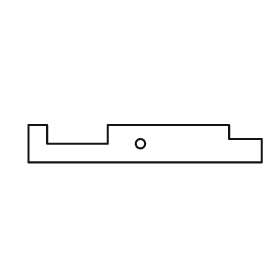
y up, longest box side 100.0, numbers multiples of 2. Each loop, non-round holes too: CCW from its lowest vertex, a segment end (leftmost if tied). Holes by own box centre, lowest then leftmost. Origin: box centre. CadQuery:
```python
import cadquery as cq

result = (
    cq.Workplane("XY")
    .moveTo(-50.0, -8.0)
    .lineTo(50.0, -8.0)
    .lineTo(50.0, 2.0)
    .lineTo(36.0, 2.0)
    .lineTo(36.0, 8.0)
    .lineTo(-16.0, 8.0)
    .lineTo(-16.0, 0.0)
    .lineTo(-42.0, 0.0)
    .lineTo(-42.0, 8.0)
    .lineTo(-50.0, 8.0)
    .close()
    .moveTo(-2.0, 0.0)
    .circle(2.0)
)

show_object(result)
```